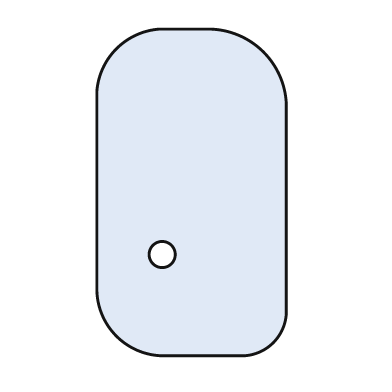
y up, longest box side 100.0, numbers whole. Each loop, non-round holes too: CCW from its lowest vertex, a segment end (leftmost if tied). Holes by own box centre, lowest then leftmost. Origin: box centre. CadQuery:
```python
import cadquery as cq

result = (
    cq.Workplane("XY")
    .moveTo(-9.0, -50.0)
    .lineTo(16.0, -50.0)
    .threePointArc((25.0, -46.0), (29.0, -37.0))
    .lineTo(29.0, 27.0)
    .threePointArc((22.0, 43.0), (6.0, 50.0))
    .lineTo(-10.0, 50.0)
    .threePointArc((-23.0, 44.0), (-29.0, 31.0))
    .lineTo(-29.0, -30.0)
    .threePointArc((-23.0, -44.0), (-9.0, -50.0))
    .close()
    .moveTo(-9.0, -19.0)
    .circle(4.0)
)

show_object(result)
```